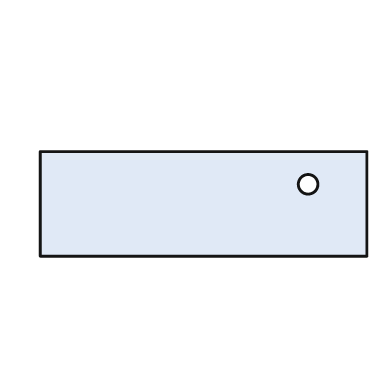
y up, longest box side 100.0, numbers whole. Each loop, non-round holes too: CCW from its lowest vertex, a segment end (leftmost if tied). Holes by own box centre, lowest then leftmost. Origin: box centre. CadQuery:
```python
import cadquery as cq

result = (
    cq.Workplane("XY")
    .moveTo(-50.0, -16.0)
    .lineTo(50.0, -16.0)
    .lineTo(50.0, 16.0)
    .lineTo(-50.0, 16.0)
    .close()
    .moveTo(32.0, 6.0)
    .circle(3.0)
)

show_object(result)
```